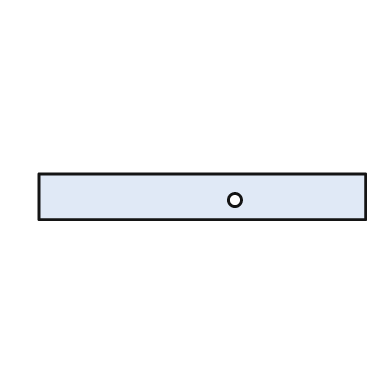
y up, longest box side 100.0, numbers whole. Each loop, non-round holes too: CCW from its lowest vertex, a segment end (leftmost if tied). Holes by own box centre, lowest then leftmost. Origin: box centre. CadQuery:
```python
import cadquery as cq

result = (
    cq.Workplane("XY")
    .moveTo(-50.0, -7.0)
    .lineTo(50.0, -7.0)
    .lineTo(50.0, 7.0)
    .lineTo(-50.0, 7.0)
    .close()
    .moveTo(10.0, -1.0)
    .circle(2.0)
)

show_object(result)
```